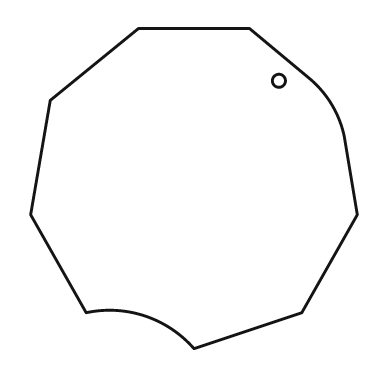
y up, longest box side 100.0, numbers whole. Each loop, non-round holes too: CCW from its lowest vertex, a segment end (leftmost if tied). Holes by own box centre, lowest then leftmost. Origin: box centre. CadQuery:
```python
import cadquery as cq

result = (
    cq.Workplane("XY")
    .moveTo(0.0, -49.0)
    .lineTo(33.0, -38.0)
    .lineTo(50.0, -8.0)
    .lineTo(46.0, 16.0)
    .threePointArc((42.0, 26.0), (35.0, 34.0))
    .lineTo(17.0, 49.0)
    .lineTo(-17.0, 49.0)
    .lineTo(-44.0, 27.0)
    .lineTo(-50.0, -8.0)
    .lineTo(-33.0, -38.0)
    .threePointArc((-15.0, -39.0), (0.0, -49.0))
    .close()
    .moveTo(26.0, 33.0)
    .circle(2.0)
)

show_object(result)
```